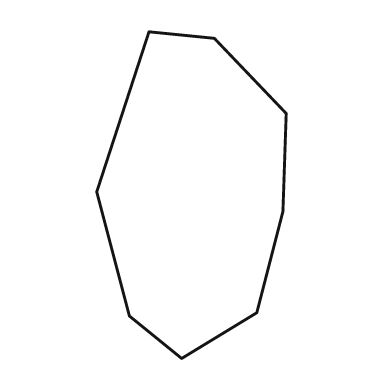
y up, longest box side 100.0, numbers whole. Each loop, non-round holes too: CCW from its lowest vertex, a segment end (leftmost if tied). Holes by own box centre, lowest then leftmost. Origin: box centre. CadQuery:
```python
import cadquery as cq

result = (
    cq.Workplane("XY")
    .moveTo(-3.0, -50.0)
    .lineTo(20.0, -36.0)
    .lineTo(28.0, -5.0)
    .lineTo(29.0, 25.0)
    .lineTo(7.0, 48.0)
    .lineTo(-13.0, 50.0)
    .lineTo(-29.0, 1.0)
    .lineTo(-19.0, -37.0)
    .close()
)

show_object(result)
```